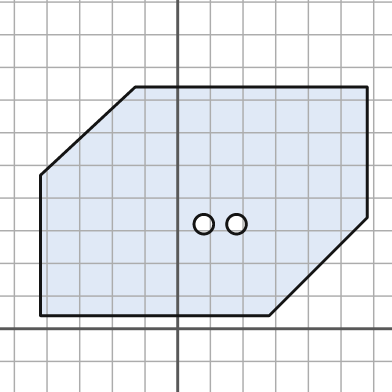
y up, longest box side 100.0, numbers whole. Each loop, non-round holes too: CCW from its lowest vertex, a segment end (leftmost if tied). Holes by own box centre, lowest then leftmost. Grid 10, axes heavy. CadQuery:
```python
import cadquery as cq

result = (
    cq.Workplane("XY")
    .moveTo(-42.0, 4.0)
    .lineTo(28.0, 4.0)
    .lineTo(58.0, 34.0)
    .lineTo(58.0, 74.0)
    .lineTo(-13.0, 74.0)
    .lineTo(-42.0, 47.0)
    .close()
    .moveTo(8.0, 32.0)
    .circle(3.0)
    .moveTo(18.0, 32.0)
    .circle(3.0)
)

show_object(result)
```